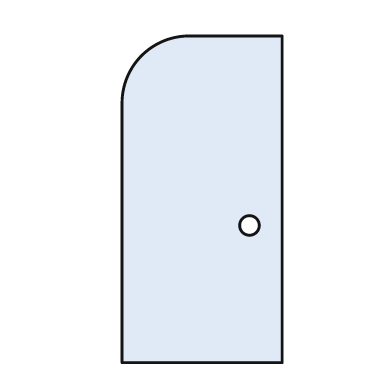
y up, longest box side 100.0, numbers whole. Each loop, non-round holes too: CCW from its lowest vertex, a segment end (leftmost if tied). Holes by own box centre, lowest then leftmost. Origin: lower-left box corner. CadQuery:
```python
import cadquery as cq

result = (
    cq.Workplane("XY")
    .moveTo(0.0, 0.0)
    .lineTo(49.0, 0.0)
    .lineTo(49.0, 100.0)
    .lineTo(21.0, 100.0)
    .threePointArc((6.0, 94.0), (0.0, 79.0))
    .close()
    .moveTo(39.0, 42.0)
    .circle(3.0)
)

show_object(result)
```